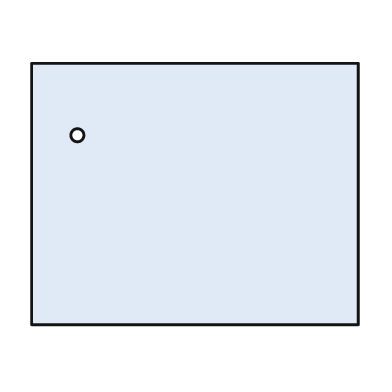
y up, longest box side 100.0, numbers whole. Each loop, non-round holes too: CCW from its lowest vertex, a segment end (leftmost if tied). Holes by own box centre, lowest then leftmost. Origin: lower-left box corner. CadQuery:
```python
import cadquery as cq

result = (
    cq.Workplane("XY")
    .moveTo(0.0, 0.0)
    .lineTo(100.0, 0.0)
    .lineTo(100.0, 80.0)
    .lineTo(0.0, 80.0)
    .close()
    .moveTo(14.0, 58.0)
    .circle(2.0)
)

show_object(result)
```